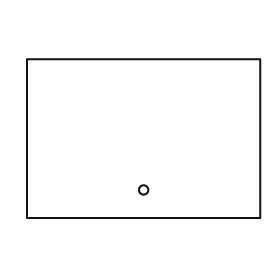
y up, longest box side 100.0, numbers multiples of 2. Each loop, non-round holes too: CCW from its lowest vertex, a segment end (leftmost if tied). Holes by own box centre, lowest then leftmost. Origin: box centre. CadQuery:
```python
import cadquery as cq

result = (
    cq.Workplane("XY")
    .moveTo(-50.0, -34.0)
    .lineTo(50.0, -34.0)
    .lineTo(50.0, 34.0)
    .lineTo(-50.0, 34.0)
    .close()
    .moveTo(0.0, -22.0)
    .circle(2.0)
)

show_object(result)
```